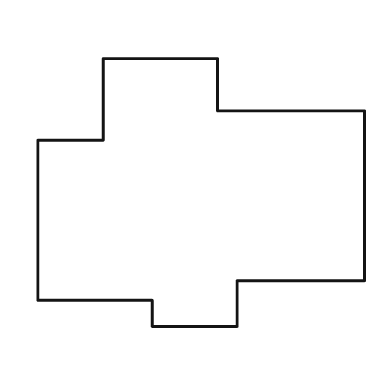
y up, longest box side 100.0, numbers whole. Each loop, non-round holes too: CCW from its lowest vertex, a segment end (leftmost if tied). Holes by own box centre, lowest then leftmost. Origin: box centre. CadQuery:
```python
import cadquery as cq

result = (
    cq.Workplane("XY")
    .moveTo(-15.0, -41.0)
    .lineTo(11.0, -41.0)
    .lineTo(11.0, -27.0)
    .lineTo(50.0, -27.0)
    .lineTo(50.0, 25.0)
    .lineTo(5.0, 25.0)
    .lineTo(5.0, 41.0)
    .lineTo(-30.0, 41.0)
    .lineTo(-30.0, 16.0)
    .lineTo(-50.0, 16.0)
    .lineTo(-50.0, -33.0)
    .lineTo(-15.0, -33.0)
    .close()
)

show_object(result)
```